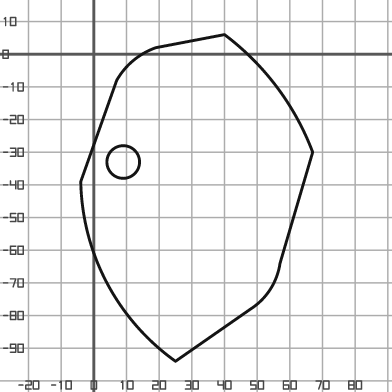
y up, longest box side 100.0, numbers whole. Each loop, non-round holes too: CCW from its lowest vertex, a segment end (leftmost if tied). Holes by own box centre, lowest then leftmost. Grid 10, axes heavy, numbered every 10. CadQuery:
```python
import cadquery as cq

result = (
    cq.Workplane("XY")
    .moveTo(25.0, -94.0)
    .lineTo(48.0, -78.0)
    .threePointArc((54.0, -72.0), (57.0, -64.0))
    .lineTo(67.0, -30.0)
    .threePointArc((56.0, -10.0), (40.0, 6.0))
    .lineTo(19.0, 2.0)
    .threePointArc((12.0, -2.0), (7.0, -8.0))
    .lineTo(-4.0, -39.0)
    .threePointArc((4.0, -70.0), (25.0, -94.0))
    .close()
    .moveTo(9.0, -33.0)
    .circle(5.0)
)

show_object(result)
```